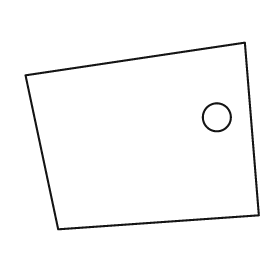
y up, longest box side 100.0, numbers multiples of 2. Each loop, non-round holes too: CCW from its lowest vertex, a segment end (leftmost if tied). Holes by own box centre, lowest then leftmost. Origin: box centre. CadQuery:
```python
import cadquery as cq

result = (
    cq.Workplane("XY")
    .moveTo(-36.0, -40.0)
    .lineTo(50.0, -34.0)
    .lineTo(44.0, 40.0)
    .lineTo(-50.0, 26.0)
    .close()
    .moveTo(32.0, 8.0)
    .circle(6.0)
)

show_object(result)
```